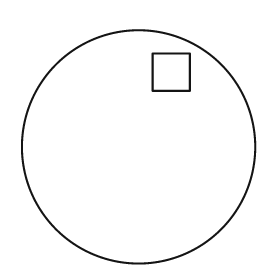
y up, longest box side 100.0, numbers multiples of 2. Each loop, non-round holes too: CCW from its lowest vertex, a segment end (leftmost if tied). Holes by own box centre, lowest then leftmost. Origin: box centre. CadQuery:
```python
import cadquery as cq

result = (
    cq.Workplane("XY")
    .moveTo(0.0, 0.0)
    .circle(50.0)
    .moveTo(6.0, 24.0)
    .lineTo(22.0, 24.0)
    .lineTo(22.0, 40.0)
    .lineTo(6.0, 40.0)
    .close()
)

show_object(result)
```